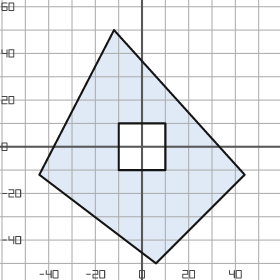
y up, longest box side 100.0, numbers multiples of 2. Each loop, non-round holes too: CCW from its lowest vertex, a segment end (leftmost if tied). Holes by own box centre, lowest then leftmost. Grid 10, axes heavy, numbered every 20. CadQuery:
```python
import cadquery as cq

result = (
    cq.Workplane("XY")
    .moveTo(6.0, -50.0)
    .lineTo(44.0, -12.0)
    .lineTo(-12.0, 50.0)
    .lineTo(-44.0, -12.0)
    .close()
    .moveTo(-10.0, -10.0)
    .lineTo(10.0, -10.0)
    .lineTo(10.0, 10.0)
    .lineTo(-10.0, 10.0)
    .close()
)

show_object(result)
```